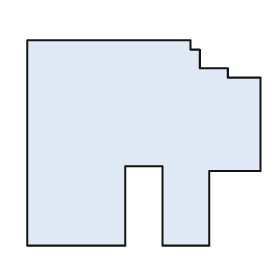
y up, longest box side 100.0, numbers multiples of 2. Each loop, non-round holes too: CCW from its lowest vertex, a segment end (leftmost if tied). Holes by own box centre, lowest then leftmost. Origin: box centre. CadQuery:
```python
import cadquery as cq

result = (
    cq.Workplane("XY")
    .moveTo(-50.0, -44.0)
    .lineTo(-8.0, -44.0)
    .lineTo(-8.0, -10.0)
    .lineTo(8.0, -10.0)
    .lineTo(8.0, -44.0)
    .lineTo(28.0, -44.0)
    .lineTo(28.0, -12.0)
    .lineTo(50.0, -12.0)
    .lineTo(50.0, 28.0)
    .lineTo(36.0, 28.0)
    .lineTo(36.0, 32.0)
    .lineTo(24.0, 32.0)
    .lineTo(24.0, 40.0)
    .lineTo(20.0, 40.0)
    .lineTo(20.0, 44.0)
    .lineTo(-50.0, 44.0)
    .close()
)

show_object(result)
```